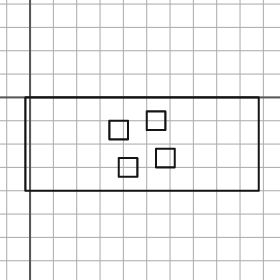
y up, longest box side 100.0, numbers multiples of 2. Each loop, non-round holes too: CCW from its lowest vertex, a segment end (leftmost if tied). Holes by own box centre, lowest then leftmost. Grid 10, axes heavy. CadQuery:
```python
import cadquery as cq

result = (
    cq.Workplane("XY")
    .moveTo(-2.0, -40.0)
    .lineTo(98.0, -40.0)
    .lineTo(98.0, 0.0)
    .lineTo(-2.0, 0.0)
    .close()
    .moveTo(38.0, -34.0)
    .lineTo(46.0, -34.0)
    .lineTo(46.0, -26.0)
    .lineTo(38.0, -26.0)
    .close()
    .moveTo(54.0, -30.0)
    .lineTo(62.0, -30.0)
    .lineTo(62.0, -22.0)
    .lineTo(54.0, -22.0)
    .close()
    .moveTo(34.0, -18.0)
    .lineTo(42.0, -18.0)
    .lineTo(42.0, -10.0)
    .lineTo(34.0, -10.0)
    .close()
    .moveTo(50.0, -14.0)
    .lineTo(58.0, -14.0)
    .lineTo(58.0, -6.0)
    .lineTo(50.0, -6.0)
    .close()
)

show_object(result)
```